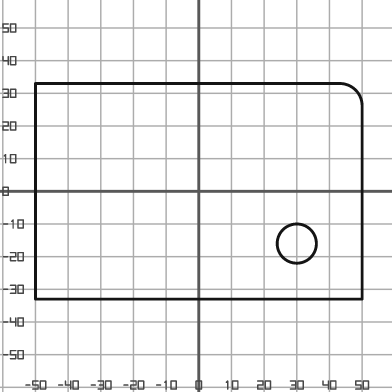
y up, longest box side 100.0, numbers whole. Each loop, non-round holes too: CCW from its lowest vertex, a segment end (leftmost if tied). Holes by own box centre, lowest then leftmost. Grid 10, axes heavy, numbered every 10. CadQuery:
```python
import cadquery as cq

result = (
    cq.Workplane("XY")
    .moveTo(-50.0, -33.0)
    .lineTo(50.0, -33.0)
    .lineTo(50.0, 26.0)
    .threePointArc((48.0, 31.0), (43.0, 33.0))
    .lineTo(-50.0, 33.0)
    .close()
    .moveTo(30.0, -16.0)
    .circle(6.0)
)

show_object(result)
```